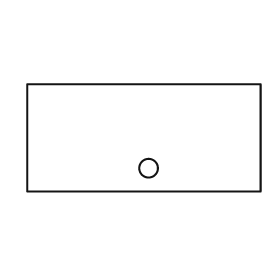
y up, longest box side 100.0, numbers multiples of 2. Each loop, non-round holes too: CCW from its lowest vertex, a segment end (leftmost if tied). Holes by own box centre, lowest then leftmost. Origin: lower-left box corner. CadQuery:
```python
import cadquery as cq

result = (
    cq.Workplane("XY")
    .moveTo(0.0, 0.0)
    .lineTo(100.0, 0.0)
    .lineTo(100.0, 46.0)
    .lineTo(0.0, 46.0)
    .close()
    .moveTo(52.0, 10.0)
    .circle(4.0)
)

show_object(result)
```